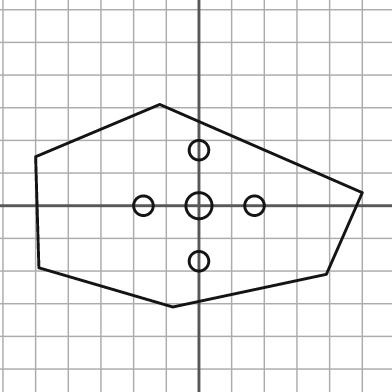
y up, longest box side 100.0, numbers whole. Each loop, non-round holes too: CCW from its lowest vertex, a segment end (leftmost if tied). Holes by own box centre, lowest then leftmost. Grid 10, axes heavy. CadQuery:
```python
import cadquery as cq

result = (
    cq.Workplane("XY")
    .moveTo(-8.0, -31.0)
    .lineTo(39.0, -21.0)
    .lineTo(50.0, 4.0)
    .lineTo(-12.0, 31.0)
    .lineTo(-50.0, 15.0)
    .lineTo(-49.0, -19.0)
    .close()
    .moveTo(0.0, -17.0)
    .circle(3.0)
    .moveTo(-17.0, 0.0)
    .circle(3.0)
    .moveTo(0.0, 0.0)
    .circle(4.0)
    .moveTo(17.0, 0.0)
    .circle(3.0)
    .moveTo(0.0, 17.0)
    .circle(3.0)
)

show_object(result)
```